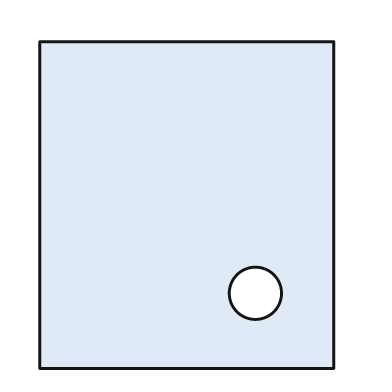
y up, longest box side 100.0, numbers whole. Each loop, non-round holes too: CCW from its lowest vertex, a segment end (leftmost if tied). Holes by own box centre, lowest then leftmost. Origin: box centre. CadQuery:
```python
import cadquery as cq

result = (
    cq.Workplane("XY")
    .moveTo(-45.0, -50.0)
    .lineTo(45.0, -50.0)
    .lineTo(45.0, 50.0)
    .lineTo(-45.0, 50.0)
    .close()
    .moveTo(21.0, -27.0)
    .circle(8.0)
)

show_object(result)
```